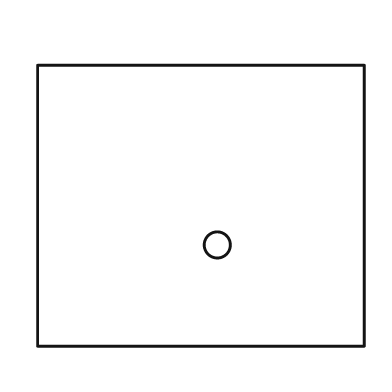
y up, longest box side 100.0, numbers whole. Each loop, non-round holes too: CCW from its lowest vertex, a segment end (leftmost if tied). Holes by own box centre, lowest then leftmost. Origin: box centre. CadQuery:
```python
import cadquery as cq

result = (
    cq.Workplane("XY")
    .moveTo(-50.0, -43.0)
    .lineTo(50.0, -43.0)
    .lineTo(50.0, 43.0)
    .lineTo(-50.0, 43.0)
    .close()
    .moveTo(5.0, -12.0)
    .circle(4.0)
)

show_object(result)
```